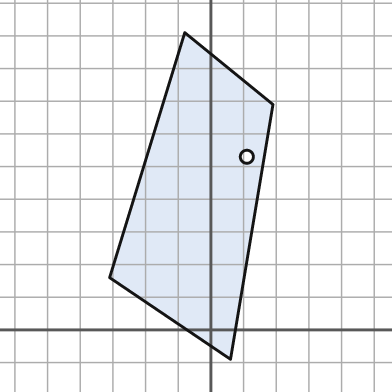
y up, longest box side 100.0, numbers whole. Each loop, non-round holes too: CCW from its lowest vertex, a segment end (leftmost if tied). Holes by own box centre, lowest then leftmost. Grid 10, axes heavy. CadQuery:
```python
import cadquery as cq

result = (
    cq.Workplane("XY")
    .moveTo(6.0, -9.0)
    .lineTo(19.0, 69.0)
    .lineTo(-8.0, 91.0)
    .lineTo(-31.0, 16.0)
    .close()
    .moveTo(11.0, 53.0)
    .circle(2.0)
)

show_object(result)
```